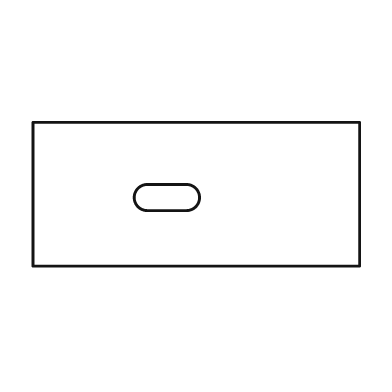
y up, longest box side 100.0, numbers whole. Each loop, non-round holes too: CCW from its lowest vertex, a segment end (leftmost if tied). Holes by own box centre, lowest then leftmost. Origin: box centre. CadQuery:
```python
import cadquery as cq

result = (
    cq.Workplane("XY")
    .moveTo(-50.0, -22.0)
    .lineTo(50.0, -22.0)
    .lineTo(50.0, 22.0)
    .lineTo(-50.0, 22.0)
    .close()
    .moveTo(-15.0, -5.0)
    .lineTo(-3.0, -5.0)
    .threePointArc((1.0, -1.0), (-3.0, 3.0))
    .lineTo(-15.0, 3.0)
    .threePointArc((-19.0, -1.0), (-15.0, -5.0))
    .close()
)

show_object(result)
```